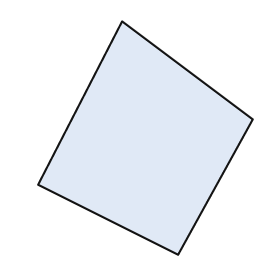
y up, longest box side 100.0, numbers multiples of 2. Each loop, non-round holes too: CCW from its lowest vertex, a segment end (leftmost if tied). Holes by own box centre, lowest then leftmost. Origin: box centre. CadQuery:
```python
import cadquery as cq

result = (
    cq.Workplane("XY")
    .moveTo(14.0, -50.0)
    .lineTo(46.0, 8.0)
    .lineTo(-10.0, 50.0)
    .lineTo(-46.0, -20.0)
    .close()
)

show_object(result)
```